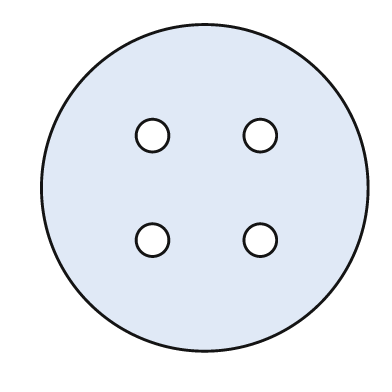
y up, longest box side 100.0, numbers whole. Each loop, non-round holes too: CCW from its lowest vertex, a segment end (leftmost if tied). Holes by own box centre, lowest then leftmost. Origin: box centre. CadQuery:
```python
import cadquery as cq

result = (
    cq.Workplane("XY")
    .moveTo(0.0, 0.0)
    .circle(50.0)
    .moveTo(-16.0, -16.0)
    .circle(5.0)
    .moveTo(17.0, -16.0)
    .circle(5.0)
    .moveTo(-16.0, 16.0)
    .circle(5.0)
    .moveTo(17.0, 16.0)
    .circle(5.0)
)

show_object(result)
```